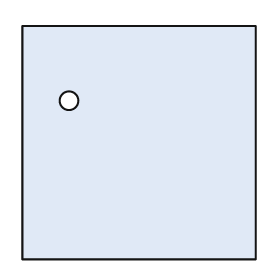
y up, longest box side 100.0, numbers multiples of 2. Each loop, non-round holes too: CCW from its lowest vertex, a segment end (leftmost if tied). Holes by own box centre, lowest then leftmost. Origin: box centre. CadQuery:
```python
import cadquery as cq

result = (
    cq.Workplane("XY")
    .moveTo(-50.0, -50.0)
    .lineTo(50.0, -50.0)
    .lineTo(50.0, 50.0)
    .lineTo(-50.0, 50.0)
    .close()
    .moveTo(-30.0, 18.0)
    .circle(4.0)
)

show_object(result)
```